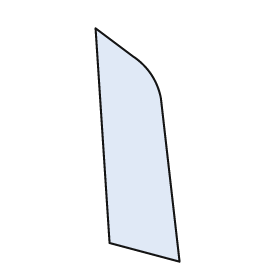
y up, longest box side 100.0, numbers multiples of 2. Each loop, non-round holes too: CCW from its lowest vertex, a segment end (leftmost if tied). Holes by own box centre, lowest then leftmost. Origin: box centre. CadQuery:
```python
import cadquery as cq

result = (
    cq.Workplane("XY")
    .moveTo(18.0, -50.0)
    .lineTo(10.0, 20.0)
    .threePointArc((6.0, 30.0), (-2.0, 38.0))
    .lineTo(-18.0, 50.0)
    .lineTo(-12.0, -42.0)
    .close()
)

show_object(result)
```